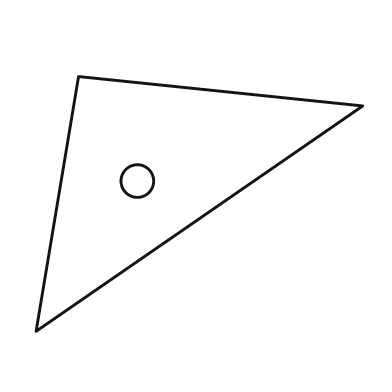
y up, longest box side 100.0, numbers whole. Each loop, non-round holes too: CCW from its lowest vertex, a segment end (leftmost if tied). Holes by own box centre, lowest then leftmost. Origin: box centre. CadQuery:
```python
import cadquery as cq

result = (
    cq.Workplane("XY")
    .moveTo(-50.0, -39.0)
    .lineTo(50.0, 30.0)
    .lineTo(-37.0, 39.0)
    .close()
    .moveTo(-19.0, 7.0)
    .circle(5.0)
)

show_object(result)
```